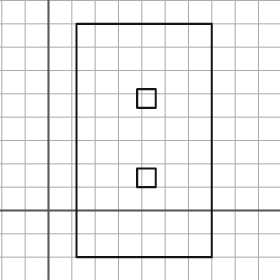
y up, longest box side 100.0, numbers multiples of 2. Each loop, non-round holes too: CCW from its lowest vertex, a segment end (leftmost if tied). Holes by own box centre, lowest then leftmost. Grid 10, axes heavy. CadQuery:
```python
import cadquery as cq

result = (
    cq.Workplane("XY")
    .moveTo(12.0, -20.0)
    .lineTo(70.0, -20.0)
    .lineTo(70.0, 80.0)
    .lineTo(12.0, 80.0)
    .close()
    .moveTo(38.0, 10.0)
    .lineTo(46.0, 10.0)
    .lineTo(46.0, 18.0)
    .lineTo(38.0, 18.0)
    .close()
    .moveTo(38.0, 44.0)
    .lineTo(46.0, 44.0)
    .lineTo(46.0, 52.0)
    .lineTo(38.0, 52.0)
    .close()
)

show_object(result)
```